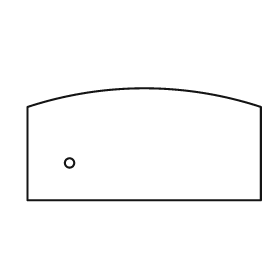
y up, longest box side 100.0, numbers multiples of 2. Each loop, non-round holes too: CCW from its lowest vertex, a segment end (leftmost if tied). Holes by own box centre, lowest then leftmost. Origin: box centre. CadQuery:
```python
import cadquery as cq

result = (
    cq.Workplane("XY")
    .moveTo(-50.0, -24.0)
    .lineTo(50.0, -24.0)
    .lineTo(50.0, 16.0)
    .threePointArc((0.0, 24.0), (-50.0, 16.0))
    .close()
    .moveTo(-32.0, -8.0)
    .circle(2.0)
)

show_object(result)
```